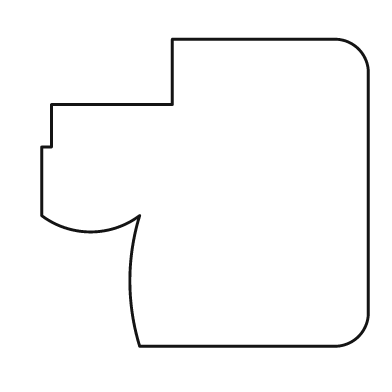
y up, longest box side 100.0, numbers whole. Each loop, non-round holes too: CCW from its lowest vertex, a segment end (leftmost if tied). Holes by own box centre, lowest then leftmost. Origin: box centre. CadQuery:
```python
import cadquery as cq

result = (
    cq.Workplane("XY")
    .moveTo(-20.0, -47.0)
    .lineTo(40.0, -47.0)
    .threePointArc((47.0, -44.0), (50.0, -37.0))
    .lineTo(50.0, 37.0)
    .threePointArc((47.0, 44.0), (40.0, 47.0))
    .lineTo(-10.0, 47.0)
    .lineTo(-10.0, 27.0)
    .lineTo(-47.0, 27.0)
    .lineTo(-47.0, 14.0)
    .lineTo(-50.0, 14.0)
    .lineTo(-50.0, -7.0)
    .threePointArc((-35.0, -12.0), (-20.0, -7.0))
    .threePointArc((-23.0, -27.0), (-20.0, -47.0))
    .close()
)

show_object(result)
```